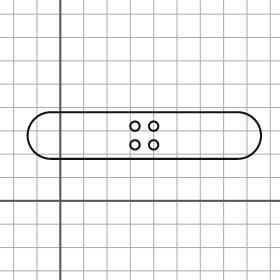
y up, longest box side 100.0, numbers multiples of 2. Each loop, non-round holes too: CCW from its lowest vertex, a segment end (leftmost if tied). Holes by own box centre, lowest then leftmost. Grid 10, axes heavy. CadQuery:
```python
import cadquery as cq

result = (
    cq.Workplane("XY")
    .moveTo(-4.0, 18.0)
    .lineTo(76.0, 18.0)
    .threePointArc((86.0, 28.0), (76.0, 38.0))
    .lineTo(-4.0, 38.0)
    .threePointArc((-14.0, 28.0), (-4.0, 18.0))
    .close()
    .moveTo(32.0, 24.0)
    .circle(2.0)
    .moveTo(40.0, 24.0)
    .circle(2.0)
    .moveTo(32.0, 32.0)
    .circle(2.0)
    .moveTo(40.0, 32.0)
    .circle(2.0)
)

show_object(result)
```